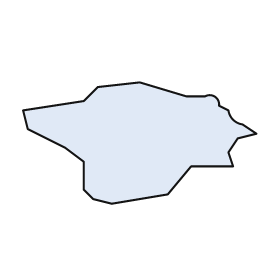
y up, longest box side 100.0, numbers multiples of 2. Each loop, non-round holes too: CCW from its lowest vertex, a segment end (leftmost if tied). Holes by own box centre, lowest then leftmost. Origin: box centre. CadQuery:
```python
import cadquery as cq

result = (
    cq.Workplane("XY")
    .moveTo(-12.0, -26.0)
    .lineTo(12.0, -22.0)
    .lineTo(22.0, -10.0)
    .lineTo(40.0, -10.0)
    .lineTo(38.0, -4.0)
    .lineTo(42.0, 2.0)
    .lineTo(50.0, 4.0)
    .lineTo(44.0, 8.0)
    .threePointArc((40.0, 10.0), (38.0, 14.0))
    .lineTo(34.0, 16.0)
    .threePointArc((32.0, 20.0), (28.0, 20.0))
    .lineTo(20.0, 20.0)
    .lineTo(0.0, 26.0)
    .lineTo(-18.0, 24.0)
    .lineTo(-24.0, 18.0)
    .lineTo(-50.0, 14.0)
    .lineTo(-48.0, 6.0)
    .lineTo(-32.0, -2.0)
    .lineTo(-24.0, -8.0)
    .lineTo(-24.0, -20.0)
    .lineTo(-20.0, -24.0)
    .close()
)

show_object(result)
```